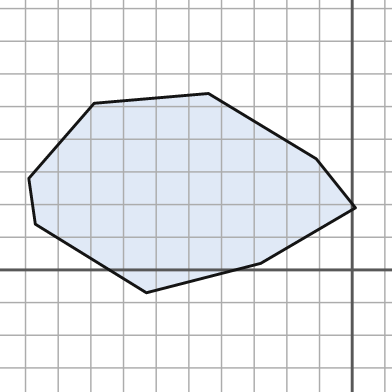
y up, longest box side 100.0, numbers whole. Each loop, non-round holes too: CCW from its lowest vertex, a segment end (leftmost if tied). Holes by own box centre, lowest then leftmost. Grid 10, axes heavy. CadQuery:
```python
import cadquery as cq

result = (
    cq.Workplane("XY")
    .moveTo(-63.0, -7.0)
    .lineTo(-28.0, 2.0)
    .lineTo(1.0, 19.0)
    .lineTo(-11.0, 34.0)
    .lineTo(-44.0, 54.0)
    .lineTo(-79.0, 51.0)
    .lineTo(-99.0, 28.0)
    .lineTo(-97.0, 14.0)
    .close()
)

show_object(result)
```